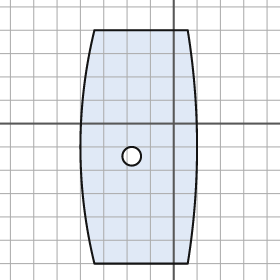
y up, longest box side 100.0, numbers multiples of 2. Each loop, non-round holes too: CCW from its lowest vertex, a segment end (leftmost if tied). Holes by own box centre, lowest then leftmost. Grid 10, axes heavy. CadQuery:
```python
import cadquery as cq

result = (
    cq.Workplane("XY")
    .moveTo(-34.0, -60.0)
    .lineTo(6.0, -60.0)
    .threePointArc((10.0, -10.0), (6.0, 40.0))
    .lineTo(-34.0, 40.0)
    .threePointArc((-40.0, -10.0), (-34.0, -60.0))
    .close()
    .moveTo(-18.0, -14.0)
    .circle(4.0)
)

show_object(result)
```